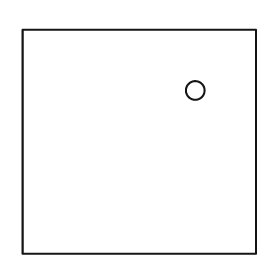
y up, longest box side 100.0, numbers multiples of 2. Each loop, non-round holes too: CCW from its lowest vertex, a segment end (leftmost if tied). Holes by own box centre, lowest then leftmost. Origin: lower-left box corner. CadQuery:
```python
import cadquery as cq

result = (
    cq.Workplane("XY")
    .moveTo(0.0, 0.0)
    .lineTo(100.0, 0.0)
    .lineTo(100.0, 96.0)
    .lineTo(0.0, 96.0)
    .close()
    .moveTo(74.0, 70.0)
    .circle(4.0)
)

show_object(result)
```